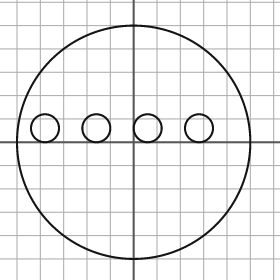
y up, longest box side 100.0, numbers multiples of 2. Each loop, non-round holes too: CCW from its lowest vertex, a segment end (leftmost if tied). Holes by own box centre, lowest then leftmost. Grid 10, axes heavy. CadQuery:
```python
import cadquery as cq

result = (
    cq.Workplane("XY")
    .moveTo(0.0, 0.0)
    .circle(50.0)
    .moveTo(-38.0, 6.0)
    .circle(6.0)
    .moveTo(-16.0, 6.0)
    .circle(6.0)
    .moveTo(6.0, 6.0)
    .circle(6.0)
    .moveTo(28.0, 6.0)
    .circle(6.0)
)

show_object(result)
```